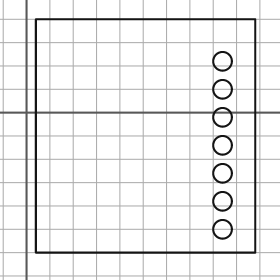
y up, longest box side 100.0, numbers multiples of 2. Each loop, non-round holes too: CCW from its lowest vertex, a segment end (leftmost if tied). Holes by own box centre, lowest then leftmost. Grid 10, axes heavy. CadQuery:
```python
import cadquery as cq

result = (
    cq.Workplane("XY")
    .moveTo(4.0, -60.0)
    .lineTo(98.0, -60.0)
    .lineTo(98.0, 40.0)
    .lineTo(4.0, 40.0)
    .close()
    .moveTo(84.0, -50.0)
    .circle(4.0)
    .moveTo(84.0, -38.0)
    .circle(4.0)
    .moveTo(84.0, -26.0)
    .circle(4.0)
    .moveTo(84.0, -14.0)
    .circle(4.0)
    .moveTo(84.0, -2.0)
    .circle(4.0)
    .moveTo(84.0, 10.0)
    .circle(4.0)
    .moveTo(84.0, 22.0)
    .circle(4.0)
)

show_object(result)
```